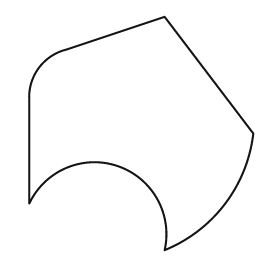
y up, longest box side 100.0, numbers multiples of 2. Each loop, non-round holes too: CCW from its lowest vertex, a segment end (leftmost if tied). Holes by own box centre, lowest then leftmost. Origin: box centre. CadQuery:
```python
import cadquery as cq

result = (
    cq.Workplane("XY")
    .moveTo(10.0, -50.0)
    .threePointArc((36.0, -30.0), (48.0, 0.0))
    .lineTo(10.0, 50.0)
    .lineTo(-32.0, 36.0)
    .threePointArc((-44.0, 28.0), (-48.0, 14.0))
    .lineTo(-48.0, -30.0)
    .threePointArc((-10.0, -14.0), (10.0, -50.0))
    .close()
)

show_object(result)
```